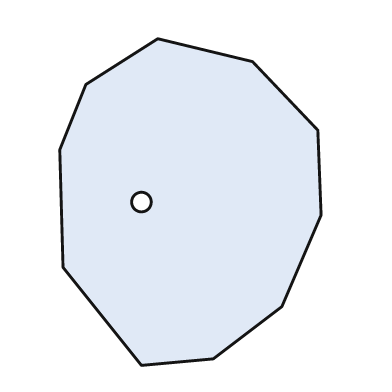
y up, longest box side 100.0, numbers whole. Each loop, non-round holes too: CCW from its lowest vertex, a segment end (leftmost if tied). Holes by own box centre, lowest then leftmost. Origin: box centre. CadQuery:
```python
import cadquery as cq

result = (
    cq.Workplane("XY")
    .moveTo(-15.0, -50.0)
    .lineTo(7.0, -48.0)
    .lineTo(28.0, -32.0)
    .lineTo(40.0, -4.0)
    .lineTo(39.0, 22.0)
    .lineTo(19.0, 43.0)
    .lineTo(-10.0, 50.0)
    .lineTo(-32.0, 36.0)
    .lineTo(-40.0, 16.0)
    .lineTo(-39.0, -20.0)
    .close()
    .moveTo(-15.0, 0.0)
    .circle(3.0)
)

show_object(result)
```